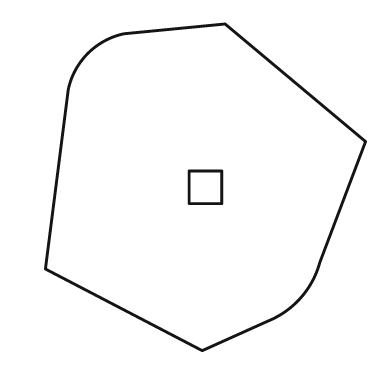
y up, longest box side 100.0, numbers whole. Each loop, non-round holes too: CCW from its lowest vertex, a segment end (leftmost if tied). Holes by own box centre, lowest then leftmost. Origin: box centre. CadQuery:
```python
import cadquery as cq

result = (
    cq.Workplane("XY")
    .moveTo(-1.0, -50.0)
    .lineTo(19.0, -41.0)
    .threePointArc((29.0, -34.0), (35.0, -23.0))
    .lineTo(49.0, 14.0)
    .lineTo(6.0, 50.0)
    .lineTo(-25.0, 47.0)
    .threePointArc((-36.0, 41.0), (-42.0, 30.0))
    .lineTo(-49.0, -25.0)
    .close()
    .moveTo(-5.0, -5.0)
    .lineTo(5.0, -5.0)
    .lineTo(5.0, 5.0)
    .lineTo(-5.0, 5.0)
    .close()
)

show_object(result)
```